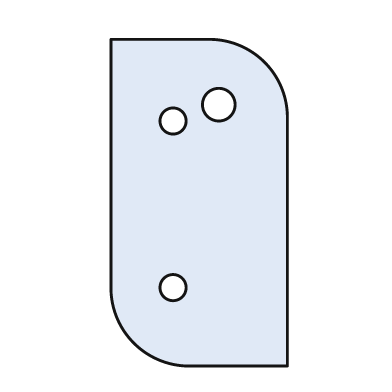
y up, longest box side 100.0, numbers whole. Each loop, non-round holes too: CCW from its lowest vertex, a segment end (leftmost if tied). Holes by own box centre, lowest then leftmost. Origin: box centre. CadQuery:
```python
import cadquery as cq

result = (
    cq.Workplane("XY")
    .moveTo(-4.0, -50.0)
    .lineTo(27.0, -50.0)
    .lineTo(27.0, 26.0)
    .threePointArc((20.0, 43.0), (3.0, 50.0))
    .lineTo(-27.0, 50.0)
    .lineTo(-27.0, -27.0)
    .threePointArc((-20.0, -43.0), (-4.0, -50.0))
    .close()
    .moveTo(-8.0, -26.0)
    .circle(4.0)
    .moveTo(-8.0, 25.0)
    .circle(4.0)
    .moveTo(6.0, 30.0)
    .circle(5.0)
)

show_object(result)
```